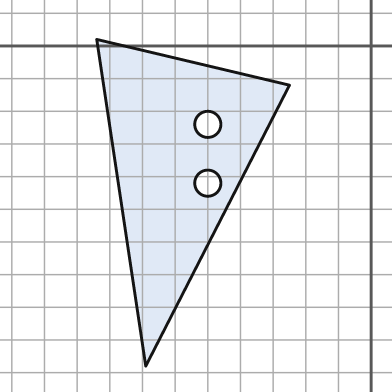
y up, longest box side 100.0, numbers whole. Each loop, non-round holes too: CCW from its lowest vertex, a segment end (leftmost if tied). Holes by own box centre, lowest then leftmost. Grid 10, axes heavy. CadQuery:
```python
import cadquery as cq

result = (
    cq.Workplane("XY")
    .moveTo(-69.0, -98.0)
    .lineTo(-25.0, -12.0)
    .lineTo(-84.0, 2.0)
    .close()
    .moveTo(-50.0, -42.0)
    .circle(4.0)
    .moveTo(-50.0, -24.0)
    .circle(4.0)
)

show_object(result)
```